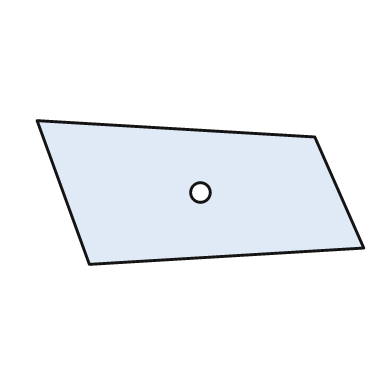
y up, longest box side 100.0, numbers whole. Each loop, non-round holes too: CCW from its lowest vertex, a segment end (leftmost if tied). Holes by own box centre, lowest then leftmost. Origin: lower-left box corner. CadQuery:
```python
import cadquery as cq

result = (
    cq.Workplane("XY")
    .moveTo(16.0, 0.0)
    .lineTo(100.0, 5.0)
    .lineTo(85.0, 39.0)
    .lineTo(0.0, 44.0)
    .close()
    .moveTo(50.0, 22.0)
    .circle(3.0)
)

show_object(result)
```